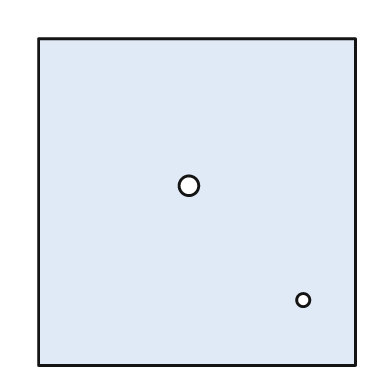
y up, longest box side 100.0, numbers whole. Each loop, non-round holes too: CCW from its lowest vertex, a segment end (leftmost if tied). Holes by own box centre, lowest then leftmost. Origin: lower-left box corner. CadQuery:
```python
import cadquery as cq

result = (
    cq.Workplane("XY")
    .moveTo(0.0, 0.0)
    .lineTo(97.0, 0.0)
    .lineTo(97.0, 100.0)
    .lineTo(0.0, 100.0)
    .close()
    .moveTo(81.0, 20.0)
    .circle(2.0)
    .moveTo(46.0, 55.0)
    .circle(3.0)
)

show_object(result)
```